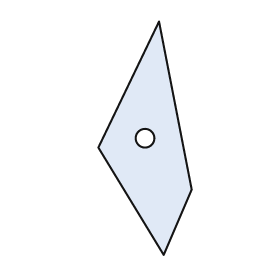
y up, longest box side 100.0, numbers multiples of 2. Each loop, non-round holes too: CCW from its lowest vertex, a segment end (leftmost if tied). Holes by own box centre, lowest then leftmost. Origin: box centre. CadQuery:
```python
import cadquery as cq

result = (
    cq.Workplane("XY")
    .moveTo(8.0, -50.0)
    .lineTo(20.0, -22.0)
    .lineTo(6.0, 50.0)
    .lineTo(-20.0, -4.0)
    .close()
    .moveTo(0.0, 0.0)
    .circle(4.0)
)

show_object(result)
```